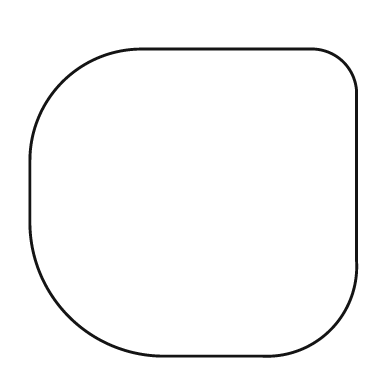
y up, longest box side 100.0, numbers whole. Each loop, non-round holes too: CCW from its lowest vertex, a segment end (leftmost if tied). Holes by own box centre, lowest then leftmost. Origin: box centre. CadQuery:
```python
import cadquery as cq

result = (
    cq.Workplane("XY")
    .moveTo(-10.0, -47.0)
    .lineTo(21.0, -47.0)
    .threePointArc((42.0, -39.0), (50.0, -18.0))
    .lineTo(50.0, 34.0)
    .threePointArc((46.0, 43.0), (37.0, 47.0))
    .lineTo(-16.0, 47.0)
    .threePointArc((-40.0, 37.0), (-50.0, 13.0))
    .lineTo(-50.0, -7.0)
    .threePointArc((-38.0, -35.0), (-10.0, -47.0))
    .close()
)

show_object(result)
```